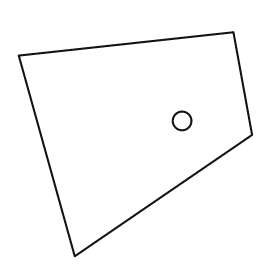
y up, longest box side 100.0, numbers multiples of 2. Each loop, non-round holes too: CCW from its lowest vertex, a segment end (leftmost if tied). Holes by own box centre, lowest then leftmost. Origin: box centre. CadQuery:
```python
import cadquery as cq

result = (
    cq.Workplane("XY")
    .moveTo(-26.0, -48.0)
    .lineTo(50.0, 4.0)
    .lineTo(42.0, 48.0)
    .lineTo(-50.0, 38.0)
    .close()
    .moveTo(20.0, 10.0)
    .circle(4.0)
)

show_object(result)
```